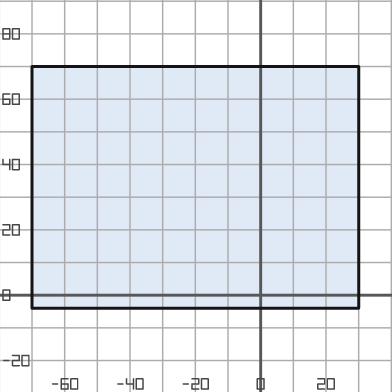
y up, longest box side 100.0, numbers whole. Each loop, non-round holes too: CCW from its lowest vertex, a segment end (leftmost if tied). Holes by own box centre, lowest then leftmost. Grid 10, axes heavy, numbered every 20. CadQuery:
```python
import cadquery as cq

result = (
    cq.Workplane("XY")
    .moveTo(-70.0, -4.0)
    .lineTo(30.0, -4.0)
    .lineTo(30.0, 70.0)
    .lineTo(-70.0, 70.0)
    .close()
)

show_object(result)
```